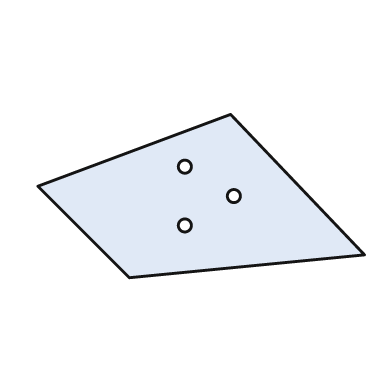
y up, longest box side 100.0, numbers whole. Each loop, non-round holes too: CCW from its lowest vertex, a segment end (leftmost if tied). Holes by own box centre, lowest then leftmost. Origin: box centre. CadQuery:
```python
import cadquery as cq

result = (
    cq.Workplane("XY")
    .moveTo(-22.0, -25.0)
    .lineTo(50.0, -18.0)
    .lineTo(9.0, 25.0)
    .lineTo(-50.0, 3.0)
    .close()
    .moveTo(-5.0, -9.0)
    .circle(2.0)
    .moveTo(10.0, 0.0)
    .circle(2.0)
    .moveTo(-5.0, 9.0)
    .circle(2.0)
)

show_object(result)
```